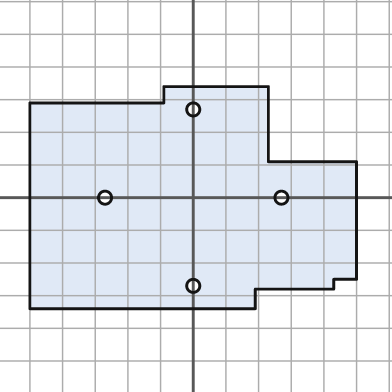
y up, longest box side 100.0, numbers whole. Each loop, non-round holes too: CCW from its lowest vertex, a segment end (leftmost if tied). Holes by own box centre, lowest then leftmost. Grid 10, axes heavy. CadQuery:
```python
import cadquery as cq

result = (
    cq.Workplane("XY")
    .moveTo(-50.0, -34.0)
    .lineTo(19.0, -34.0)
    .lineTo(19.0, -28.0)
    .lineTo(43.0, -28.0)
    .lineTo(43.0, -25.0)
    .lineTo(50.0, -25.0)
    .lineTo(50.0, 11.0)
    .lineTo(23.0, 11.0)
    .lineTo(23.0, 34.0)
    .lineTo(-9.0, 34.0)
    .lineTo(-9.0, 29.0)
    .lineTo(-50.0, 29.0)
    .close()
    .moveTo(0.0, -27.0)
    .circle(2.0)
    .moveTo(-27.0, 0.0)
    .circle(2.0)
    .moveTo(27.0, 0.0)
    .circle(2.0)
    .moveTo(0.0, 27.0)
    .circle(2.0)
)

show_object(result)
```